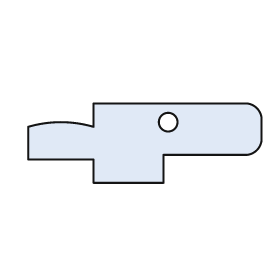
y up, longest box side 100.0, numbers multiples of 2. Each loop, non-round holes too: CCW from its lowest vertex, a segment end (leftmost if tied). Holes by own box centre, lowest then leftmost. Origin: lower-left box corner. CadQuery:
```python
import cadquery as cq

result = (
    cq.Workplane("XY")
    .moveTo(28.0, 0.0)
    .lineTo(58.0, 0.0)
    .lineTo(58.0, 12.0)
    .lineTo(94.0, 12.0)
    .threePointArc((98.0, 14.0), (100.0, 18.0))
    .lineTo(100.0, 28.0)
    .threePointArc((98.0, 32.0), (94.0, 34.0))
    .lineTo(28.0, 34.0)
    .lineTo(28.0, 24.0)
    .threePointArc((14.0, 26.0), (0.0, 24.0))
    .lineTo(0.0, 10.0)
    .lineTo(28.0, 10.0)
    .close()
    .moveTo(60.0, 26.0)
    .circle(4.0)
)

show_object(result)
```